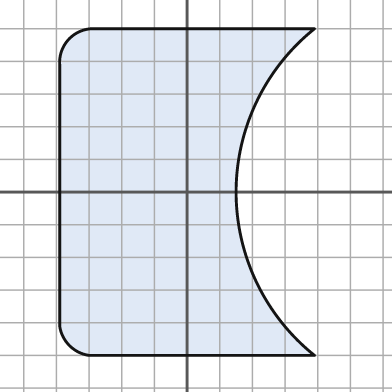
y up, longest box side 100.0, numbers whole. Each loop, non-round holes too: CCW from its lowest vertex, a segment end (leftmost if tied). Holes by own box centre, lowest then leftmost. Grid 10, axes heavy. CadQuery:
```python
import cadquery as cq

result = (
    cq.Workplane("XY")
    .moveTo(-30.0, -50.0)
    .lineTo(39.0, -50.0)
    .threePointArc((15.0, 0.0), (39.0, 50.0))
    .lineTo(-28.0, 50.0)
    .threePointArc((-36.0, 47.0), (-39.0, 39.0))
    .lineTo(-39.0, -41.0)
    .threePointArc((-36.0, -47.0), (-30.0, -50.0))
    .close()
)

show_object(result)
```